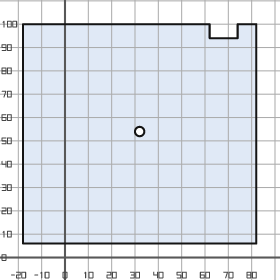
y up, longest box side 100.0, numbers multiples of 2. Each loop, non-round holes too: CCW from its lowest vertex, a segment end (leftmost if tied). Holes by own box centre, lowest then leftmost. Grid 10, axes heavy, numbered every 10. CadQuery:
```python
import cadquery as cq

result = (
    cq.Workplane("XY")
    .moveTo(-18.0, 6.0)
    .lineTo(82.0, 6.0)
    .lineTo(82.0, 100.0)
    .lineTo(74.0, 100.0)
    .lineTo(74.0, 94.0)
    .lineTo(62.0, 94.0)
    .lineTo(62.0, 100.0)
    .lineTo(-18.0, 100.0)
    .close()
    .moveTo(32.0, 54.0)
    .circle(2.0)
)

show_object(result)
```